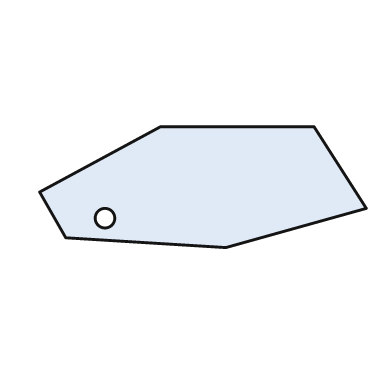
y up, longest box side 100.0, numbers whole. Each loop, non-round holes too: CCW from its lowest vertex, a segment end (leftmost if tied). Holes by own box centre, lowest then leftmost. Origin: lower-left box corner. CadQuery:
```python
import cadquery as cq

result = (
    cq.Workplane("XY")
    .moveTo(57.0, 0.0)
    .lineTo(100.0, 12.0)
    .lineTo(84.0, 37.0)
    .lineTo(37.0, 37.0)
    .lineTo(0.0, 17.0)
    .lineTo(8.0, 3.0)
    .close()
    .moveTo(20.0, 9.0)
    .circle(3.0)
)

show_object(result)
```